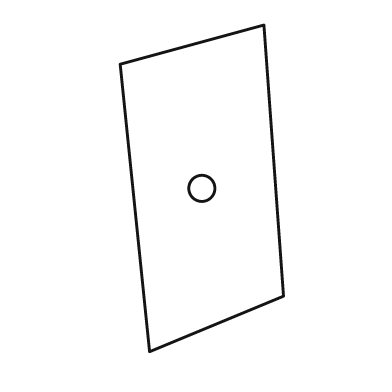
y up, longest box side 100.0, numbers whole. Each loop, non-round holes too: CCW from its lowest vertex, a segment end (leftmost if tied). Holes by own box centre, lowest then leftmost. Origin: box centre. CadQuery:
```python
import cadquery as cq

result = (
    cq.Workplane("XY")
    .moveTo(-16.0, -50.0)
    .lineTo(25.0, -33.0)
    .lineTo(19.0, 50.0)
    .lineTo(-25.0, 38.0)
    .close()
    .moveTo(0.0, 0.0)
    .circle(4.0)
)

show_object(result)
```